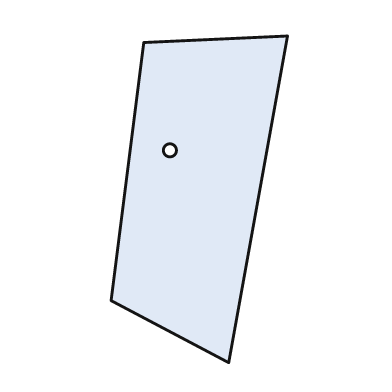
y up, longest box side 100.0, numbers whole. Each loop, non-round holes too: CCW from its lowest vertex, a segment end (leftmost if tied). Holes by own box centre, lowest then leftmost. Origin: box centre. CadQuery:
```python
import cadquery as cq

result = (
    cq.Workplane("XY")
    .moveTo(9.0, -50.0)
    .lineTo(27.0, 50.0)
    .lineTo(-17.0, 48.0)
    .lineTo(-27.0, -31.0)
    .close()
    .moveTo(-9.0, 15.0)
    .circle(2.0)
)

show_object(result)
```